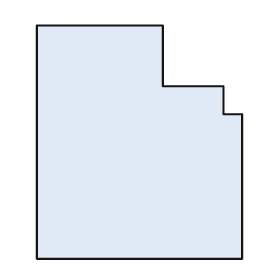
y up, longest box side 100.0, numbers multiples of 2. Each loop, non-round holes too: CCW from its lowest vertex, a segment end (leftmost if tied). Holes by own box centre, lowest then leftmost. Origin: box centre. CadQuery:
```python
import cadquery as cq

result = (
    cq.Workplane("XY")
    .moveTo(-44.0, -50.0)
    .lineTo(44.0, -50.0)
    .lineTo(44.0, 12.0)
    .lineTo(36.0, 12.0)
    .lineTo(36.0, 24.0)
    .lineTo(10.0, 24.0)
    .lineTo(10.0, 50.0)
    .lineTo(-44.0, 50.0)
    .close()
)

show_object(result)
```